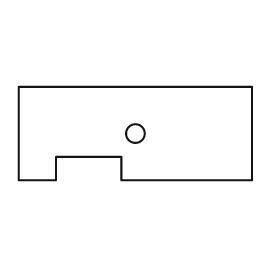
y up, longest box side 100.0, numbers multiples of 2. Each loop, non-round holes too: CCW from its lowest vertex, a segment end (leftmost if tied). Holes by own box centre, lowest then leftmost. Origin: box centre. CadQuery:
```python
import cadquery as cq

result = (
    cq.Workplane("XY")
    .moveTo(-50.0, -20.0)
    .lineTo(-34.0, -20.0)
    .lineTo(-34.0, -10.0)
    .lineTo(-6.0, -10.0)
    .lineTo(-6.0, -20.0)
    .lineTo(50.0, -20.0)
    .lineTo(50.0, 20.0)
    .lineTo(-50.0, 20.0)
    .close()
    .moveTo(0.0, 0.0)
    .circle(4.0)
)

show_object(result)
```